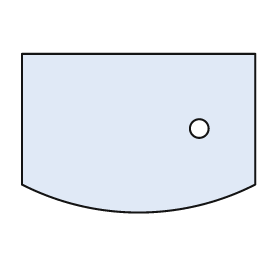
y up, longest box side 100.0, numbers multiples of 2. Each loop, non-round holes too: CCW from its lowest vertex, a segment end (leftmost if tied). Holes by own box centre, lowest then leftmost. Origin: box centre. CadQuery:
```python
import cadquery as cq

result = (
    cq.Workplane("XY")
    .moveTo(-50.0, -22.0)
    .threePointArc((0.0, -34.0), (50.0, -22.0))
    .lineTo(50.0, 34.0)
    .lineTo(-50.0, 34.0)
    .close()
    .moveTo(26.0, 2.0)
    .circle(4.0)
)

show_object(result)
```